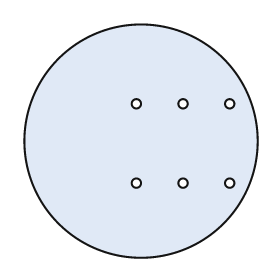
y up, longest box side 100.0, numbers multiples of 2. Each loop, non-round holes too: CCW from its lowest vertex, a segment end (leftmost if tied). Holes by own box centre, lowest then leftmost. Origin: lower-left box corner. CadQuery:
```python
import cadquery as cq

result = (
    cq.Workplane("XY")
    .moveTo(50.0, 50.0)
    .circle(50.0)
    .moveTo(48.0, 32.0)
    .circle(2.0)
    .moveTo(68.0, 32.0)
    .circle(2.0)
    .moveTo(88.0, 32.0)
    .circle(2.0)
    .moveTo(48.0, 66.0)
    .circle(2.0)
    .moveTo(68.0, 66.0)
    .circle(2.0)
    .moveTo(88.0, 66.0)
    .circle(2.0)
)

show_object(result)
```